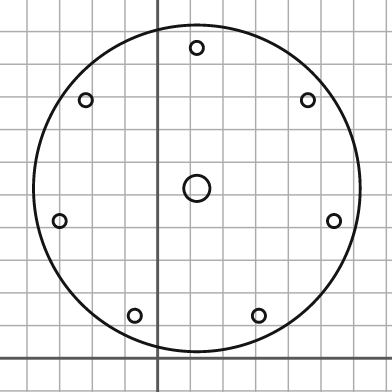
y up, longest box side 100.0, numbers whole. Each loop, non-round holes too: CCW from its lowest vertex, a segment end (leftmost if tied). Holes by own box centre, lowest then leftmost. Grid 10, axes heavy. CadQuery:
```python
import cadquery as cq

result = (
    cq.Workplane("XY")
    .moveTo(12.0, 52.0)
    .circle(50.0)
    .moveTo(-7.0, 13.0)
    .circle(2.0)
    .moveTo(31.0, 13.0)
    .circle(2.0)
    .moveTo(-30.0, 42.0)
    .circle(2.0)
    .moveTo(54.0, 42.0)
    .circle(2.0)
    .moveTo(12.0, 52.0)
    .circle(4.0)
    .moveTo(-22.0, 79.0)
    .circle(2.0)
    .moveTo(46.0, 79.0)
    .circle(2.0)
    .moveTo(12.0, 95.0)
    .circle(2.0)
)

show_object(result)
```